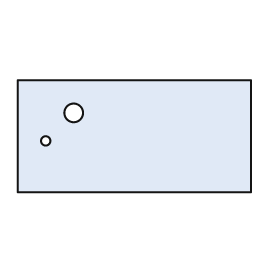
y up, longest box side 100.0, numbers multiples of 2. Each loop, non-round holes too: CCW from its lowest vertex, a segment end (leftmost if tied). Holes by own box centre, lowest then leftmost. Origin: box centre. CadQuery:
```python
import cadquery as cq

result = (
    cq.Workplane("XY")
    .moveTo(-50.0, -24.0)
    .lineTo(50.0, -24.0)
    .lineTo(50.0, 24.0)
    .lineTo(-50.0, 24.0)
    .close()
    .moveTo(-38.0, -2.0)
    .circle(2.0)
    .moveTo(-26.0, 10.0)
    .circle(4.0)
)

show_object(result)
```